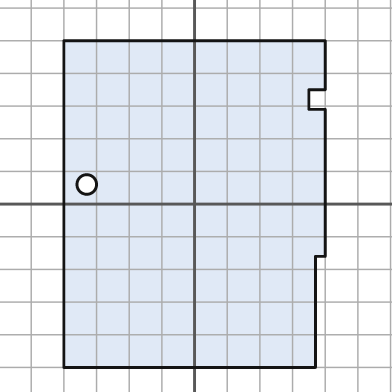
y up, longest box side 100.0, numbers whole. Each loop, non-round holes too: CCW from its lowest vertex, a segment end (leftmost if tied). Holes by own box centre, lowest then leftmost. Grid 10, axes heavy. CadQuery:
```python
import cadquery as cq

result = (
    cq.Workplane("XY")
    .moveTo(-40.0, -50.0)
    .lineTo(37.0, -50.0)
    .lineTo(37.0, -16.0)
    .lineTo(40.0, -16.0)
    .lineTo(40.0, 29.0)
    .lineTo(35.0, 29.0)
    .lineTo(35.0, 35.0)
    .lineTo(40.0, 35.0)
    .lineTo(40.0, 50.0)
    .lineTo(-40.0, 50.0)
    .close()
    .moveTo(-33.0, 6.0)
    .circle(3.0)
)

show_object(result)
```